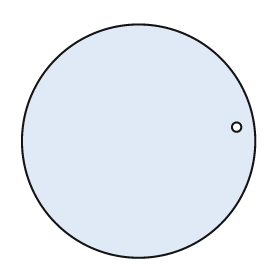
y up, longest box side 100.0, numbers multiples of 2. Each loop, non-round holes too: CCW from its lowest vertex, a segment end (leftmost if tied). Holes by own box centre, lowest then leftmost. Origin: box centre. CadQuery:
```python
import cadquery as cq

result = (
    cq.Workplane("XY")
    .moveTo(0.0, 0.0)
    .circle(50.0)
    .moveTo(42.0, 6.0)
    .circle(2.0)
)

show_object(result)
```